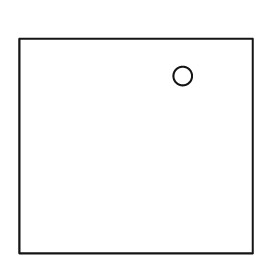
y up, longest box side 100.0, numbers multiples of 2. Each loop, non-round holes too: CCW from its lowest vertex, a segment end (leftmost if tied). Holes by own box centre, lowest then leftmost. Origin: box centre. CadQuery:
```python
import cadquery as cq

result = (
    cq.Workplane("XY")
    .moveTo(-50.0, -46.0)
    .lineTo(50.0, -46.0)
    .lineTo(50.0, 46.0)
    .lineTo(-50.0, 46.0)
    .close()
    .moveTo(20.0, 30.0)
    .circle(4.0)
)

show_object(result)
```